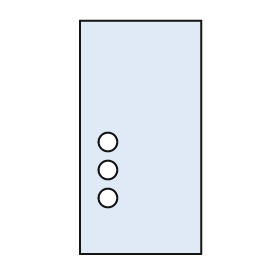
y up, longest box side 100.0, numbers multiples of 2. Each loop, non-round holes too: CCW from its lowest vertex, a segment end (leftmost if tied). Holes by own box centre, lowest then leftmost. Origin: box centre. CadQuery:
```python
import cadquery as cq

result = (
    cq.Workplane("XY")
    .moveTo(-26.0, -50.0)
    .lineTo(26.0, -50.0)
    .lineTo(26.0, 50.0)
    .lineTo(-26.0, 50.0)
    .close()
    .moveTo(-14.0, -26.0)
    .circle(4.0)
    .moveTo(-14.0, -14.0)
    .circle(4.0)
    .moveTo(-14.0, -2.0)
    .circle(4.0)
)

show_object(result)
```